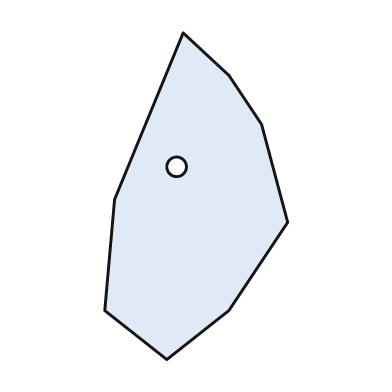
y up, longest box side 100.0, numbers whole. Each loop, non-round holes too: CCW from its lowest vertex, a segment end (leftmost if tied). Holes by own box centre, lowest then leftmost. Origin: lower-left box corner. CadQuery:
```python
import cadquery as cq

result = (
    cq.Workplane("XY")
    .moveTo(19.0, 0.0)
    .lineTo(38.0, 15.0)
    .lineTo(56.0, 42.0)
    .lineTo(48.0, 72.0)
    .lineTo(38.0, 87.0)
    .lineTo(24.0, 100.0)
    .lineTo(3.0, 49.0)
    .lineTo(0.0, 15.0)
    .close()
    .moveTo(22.0, 59.0)
    .circle(3.0)
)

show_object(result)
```